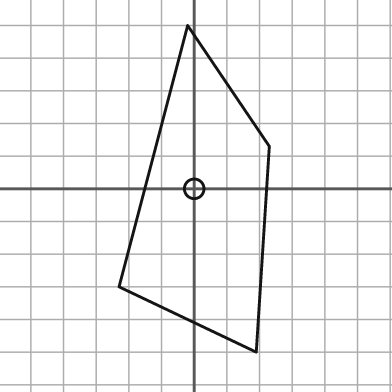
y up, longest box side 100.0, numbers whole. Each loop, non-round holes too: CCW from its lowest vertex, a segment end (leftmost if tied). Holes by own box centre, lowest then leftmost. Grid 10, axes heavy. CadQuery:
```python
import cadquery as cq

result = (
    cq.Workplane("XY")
    .moveTo(19.0, -50.0)
    .lineTo(23.0, 13.0)
    .lineTo(-2.0, 50.0)
    .lineTo(-23.0, -30.0)
    .close()
    .moveTo(0.0, 0.0)
    .circle(3.0)
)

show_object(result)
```